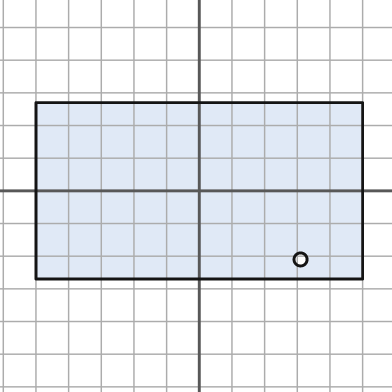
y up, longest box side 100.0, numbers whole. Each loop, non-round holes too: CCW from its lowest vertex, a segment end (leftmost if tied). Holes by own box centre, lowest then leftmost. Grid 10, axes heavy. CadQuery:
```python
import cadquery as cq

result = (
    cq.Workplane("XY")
    .moveTo(-50.0, -27.0)
    .lineTo(50.0, -27.0)
    .lineTo(50.0, 27.0)
    .lineTo(-50.0, 27.0)
    .close()
    .moveTo(31.0, -21.0)
    .circle(2.0)
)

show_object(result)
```